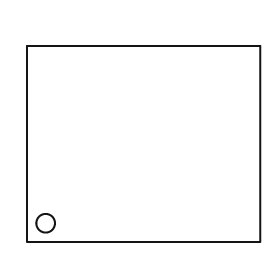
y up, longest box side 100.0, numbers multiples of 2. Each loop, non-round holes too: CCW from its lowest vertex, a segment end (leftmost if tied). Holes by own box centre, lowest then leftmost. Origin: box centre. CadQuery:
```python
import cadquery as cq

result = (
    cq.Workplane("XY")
    .moveTo(-50.0, -42.0)
    .lineTo(50.0, -42.0)
    .lineTo(50.0, 42.0)
    .lineTo(-50.0, 42.0)
    .close()
    .moveTo(-42.0, -34.0)
    .circle(4.0)
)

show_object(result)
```